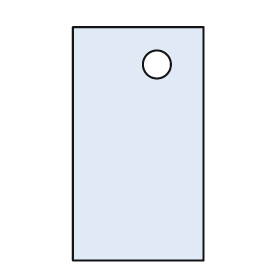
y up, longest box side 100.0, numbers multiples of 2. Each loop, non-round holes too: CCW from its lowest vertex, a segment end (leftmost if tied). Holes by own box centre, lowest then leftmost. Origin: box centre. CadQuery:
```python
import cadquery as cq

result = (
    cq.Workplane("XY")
    .moveTo(-28.0, -50.0)
    .lineTo(28.0, -50.0)
    .lineTo(28.0, 50.0)
    .lineTo(-28.0, 50.0)
    .close()
    .moveTo(8.0, 34.0)
    .circle(6.0)
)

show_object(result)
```